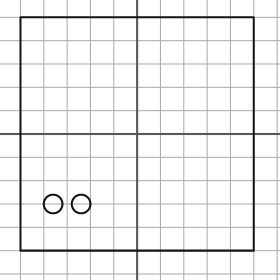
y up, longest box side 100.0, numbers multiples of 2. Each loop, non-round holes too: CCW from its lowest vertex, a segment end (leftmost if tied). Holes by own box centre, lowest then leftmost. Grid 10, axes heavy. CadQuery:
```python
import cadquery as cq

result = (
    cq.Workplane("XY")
    .moveTo(-50.0, -50.0)
    .lineTo(50.0, -50.0)
    .lineTo(50.0, 50.0)
    .lineTo(-50.0, 50.0)
    .close()
    .moveTo(-36.0, -30.0)
    .circle(4.0)
    .moveTo(-24.0, -30.0)
    .circle(4.0)
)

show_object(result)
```